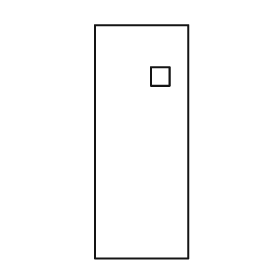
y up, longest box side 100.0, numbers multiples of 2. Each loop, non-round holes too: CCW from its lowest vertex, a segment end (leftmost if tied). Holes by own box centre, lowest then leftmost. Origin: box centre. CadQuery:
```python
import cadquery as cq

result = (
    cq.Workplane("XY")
    .moveTo(-20.0, -50.0)
    .lineTo(20.0, -50.0)
    .lineTo(20.0, 50.0)
    .lineTo(-20.0, 50.0)
    .close()
    .moveTo(4.0, 24.0)
    .lineTo(12.0, 24.0)
    .lineTo(12.0, 32.0)
    .lineTo(4.0, 32.0)
    .close()
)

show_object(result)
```